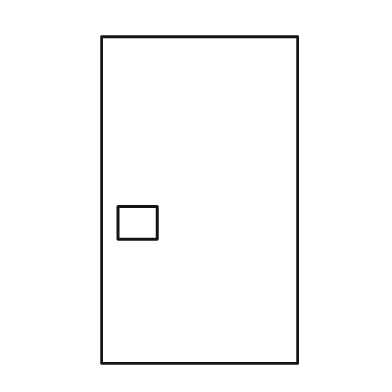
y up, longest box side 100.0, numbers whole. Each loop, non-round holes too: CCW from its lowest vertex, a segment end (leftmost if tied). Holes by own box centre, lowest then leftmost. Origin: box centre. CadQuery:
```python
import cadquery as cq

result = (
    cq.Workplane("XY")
    .moveTo(-30.0, -50.0)
    .lineTo(30.0, -50.0)
    .lineTo(30.0, 50.0)
    .lineTo(-30.0, 50.0)
    .close()
    .moveTo(-25.0, -12.0)
    .lineTo(-13.0, -12.0)
    .lineTo(-13.0, -2.0)
    .lineTo(-25.0, -2.0)
    .close()
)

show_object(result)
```